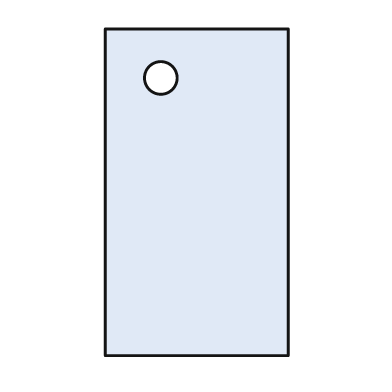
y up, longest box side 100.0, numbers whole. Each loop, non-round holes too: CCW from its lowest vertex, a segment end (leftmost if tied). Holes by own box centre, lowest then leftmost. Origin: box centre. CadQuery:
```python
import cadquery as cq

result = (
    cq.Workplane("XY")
    .moveTo(-28.0, -50.0)
    .lineTo(28.0, -50.0)
    .lineTo(28.0, 50.0)
    .lineTo(-28.0, 50.0)
    .close()
    .moveTo(-11.0, 35.0)
    .circle(5.0)
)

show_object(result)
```